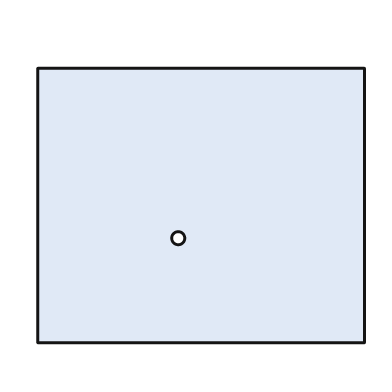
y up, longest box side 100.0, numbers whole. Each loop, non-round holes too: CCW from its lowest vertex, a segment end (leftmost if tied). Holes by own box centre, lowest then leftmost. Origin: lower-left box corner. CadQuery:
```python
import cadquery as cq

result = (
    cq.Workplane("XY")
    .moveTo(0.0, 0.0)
    .lineTo(100.0, 0.0)
    .lineTo(100.0, 84.0)
    .lineTo(0.0, 84.0)
    .close()
    .moveTo(43.0, 32.0)
    .circle(2.0)
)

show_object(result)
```